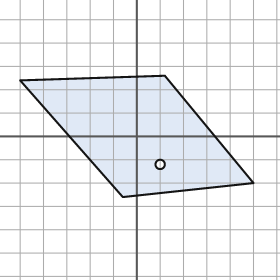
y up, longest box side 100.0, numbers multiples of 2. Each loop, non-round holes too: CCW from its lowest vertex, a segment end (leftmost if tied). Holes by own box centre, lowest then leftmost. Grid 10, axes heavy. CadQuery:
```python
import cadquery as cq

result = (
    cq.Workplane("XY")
    .moveTo(-6.0, -26.0)
    .lineTo(50.0, -20.0)
    .lineTo(12.0, 26.0)
    .lineTo(-50.0, 24.0)
    .close()
    .moveTo(10.0, -12.0)
    .circle(2.0)
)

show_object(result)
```